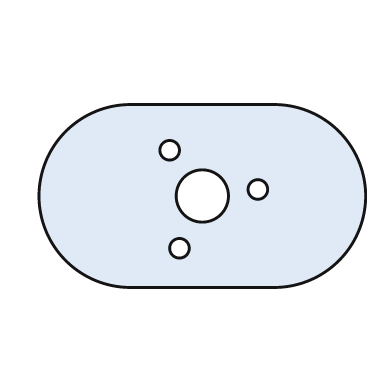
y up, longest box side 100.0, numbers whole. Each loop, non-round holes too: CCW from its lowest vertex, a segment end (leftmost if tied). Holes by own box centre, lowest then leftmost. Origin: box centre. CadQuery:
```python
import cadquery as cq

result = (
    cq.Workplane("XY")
    .moveTo(-22.0, -28.0)
    .lineTo(22.0, -28.0)
    .threePointArc((50.0, 0.0), (22.0, 28.0))
    .lineTo(-22.0, 28.0)
    .threePointArc((-50.0, 0.0), (-22.0, -28.0))
    .close()
    .moveTo(-7.0, -16.0)
    .circle(3.0)
    .moveTo(0.0, 0.0)
    .circle(8.0)
    .moveTo(17.0, 2.0)
    .circle(3.0)
    .moveTo(-10.0, 14.0)
    .circle(3.0)
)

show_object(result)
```